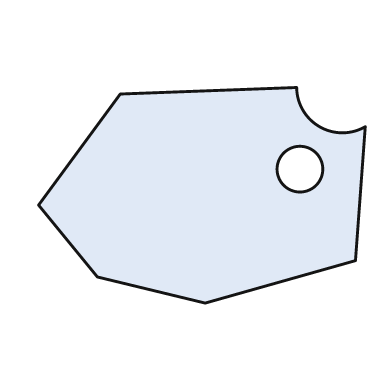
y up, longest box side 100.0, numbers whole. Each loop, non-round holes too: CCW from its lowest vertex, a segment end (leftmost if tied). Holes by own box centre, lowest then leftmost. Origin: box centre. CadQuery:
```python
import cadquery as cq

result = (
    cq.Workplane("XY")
    .moveTo(1.0, -33.0)
    .lineTo(47.0, -20.0)
    .lineTo(50.0, 21.0)
    .threePointArc((36.0, 21.0), (29.0, 33.0))
    .lineTo(-25.0, 31.0)
    .lineTo(-50.0, -3.0)
    .lineTo(-32.0, -25.0)
    .close()
    .moveTo(30.0, 8.0)
    .circle(7.0)
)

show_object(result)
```